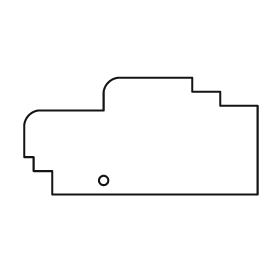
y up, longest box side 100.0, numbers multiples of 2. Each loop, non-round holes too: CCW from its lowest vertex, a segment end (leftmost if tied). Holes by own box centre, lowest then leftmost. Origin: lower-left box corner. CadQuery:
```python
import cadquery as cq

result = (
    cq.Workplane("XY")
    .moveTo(12.0, 0.0)
    .lineTo(100.0, 0.0)
    .lineTo(100.0, 38.0)
    .lineTo(84.0, 38.0)
    .lineTo(84.0, 44.0)
    .lineTo(72.0, 44.0)
    .lineTo(72.0, 50.0)
    .lineTo(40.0, 50.0)
    .threePointArc((36.0, 48.0), (34.0, 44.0))
    .lineTo(34.0, 36.0)
    .lineTo(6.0, 36.0)
    .threePointArc((2.0, 34.0), (0.0, 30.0))
    .lineTo(0.0, 16.0)
    .lineTo(4.0, 16.0)
    .lineTo(4.0, 10.0)
    .lineTo(12.0, 10.0)
    .close()
    .moveTo(34.0, 6.0)
    .circle(2.0)
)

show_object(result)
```